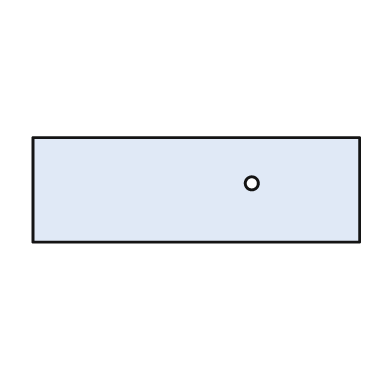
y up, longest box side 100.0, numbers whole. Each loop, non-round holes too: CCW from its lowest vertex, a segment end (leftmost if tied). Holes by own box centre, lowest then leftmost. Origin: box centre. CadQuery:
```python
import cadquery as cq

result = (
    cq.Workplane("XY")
    .moveTo(-50.0, -16.0)
    .lineTo(50.0, -16.0)
    .lineTo(50.0, 16.0)
    .lineTo(-50.0, 16.0)
    .close()
    .moveTo(17.0, 2.0)
    .circle(2.0)
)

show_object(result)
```